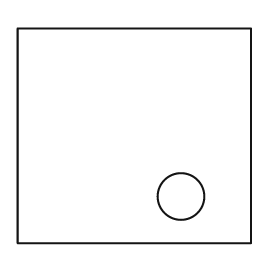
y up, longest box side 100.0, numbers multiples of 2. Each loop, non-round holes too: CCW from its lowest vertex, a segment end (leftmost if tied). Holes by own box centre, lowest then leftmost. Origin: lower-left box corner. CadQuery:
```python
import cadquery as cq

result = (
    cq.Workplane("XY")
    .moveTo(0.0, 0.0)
    .lineTo(100.0, 0.0)
    .lineTo(100.0, 92.0)
    .lineTo(0.0, 92.0)
    .close()
    .moveTo(70.0, 20.0)
    .circle(10.0)
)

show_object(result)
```